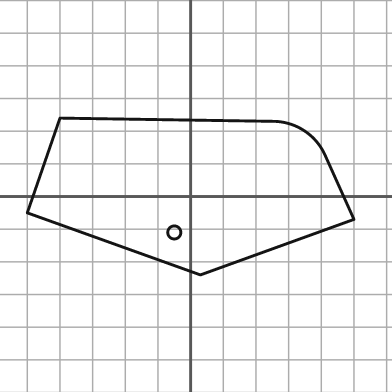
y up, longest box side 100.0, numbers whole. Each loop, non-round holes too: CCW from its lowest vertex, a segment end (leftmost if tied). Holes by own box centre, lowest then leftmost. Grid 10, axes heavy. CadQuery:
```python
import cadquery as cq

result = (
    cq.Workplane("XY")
    .moveTo(3.0, -24.0)
    .lineTo(50.0, -7.0)
    .lineTo(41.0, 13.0)
    .threePointArc((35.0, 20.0), (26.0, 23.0))
    .lineTo(-40.0, 24.0)
    .lineTo(-50.0, -5.0)
    .close()
    .moveTo(-5.0, -11.0)
    .circle(2.0)
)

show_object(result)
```